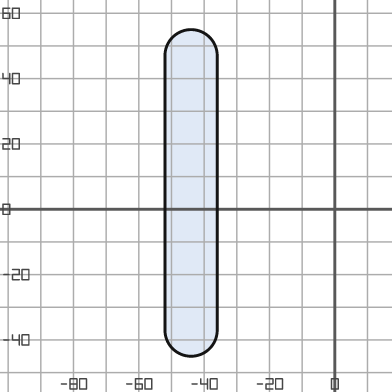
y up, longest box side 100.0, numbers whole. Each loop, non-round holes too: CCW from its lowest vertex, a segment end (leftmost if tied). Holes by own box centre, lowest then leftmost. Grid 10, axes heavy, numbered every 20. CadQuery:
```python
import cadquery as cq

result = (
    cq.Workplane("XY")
    .moveTo(-52.0, -37.0)
    .threePointArc((-44.0, -45.0), (-36.0, -37.0))
    .lineTo(-36.0, 47.0)
    .threePointArc((-44.0, 55.0), (-52.0, 47.0))
    .close()
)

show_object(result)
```